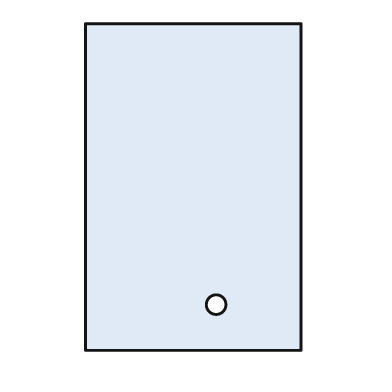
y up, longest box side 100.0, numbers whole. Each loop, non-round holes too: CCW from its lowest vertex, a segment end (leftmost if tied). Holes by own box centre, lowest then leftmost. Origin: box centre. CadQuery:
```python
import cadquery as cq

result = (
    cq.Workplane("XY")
    .moveTo(-33.0, -50.0)
    .lineTo(33.0, -50.0)
    .lineTo(33.0, 50.0)
    .lineTo(-33.0, 50.0)
    .close()
    .moveTo(7.0, -36.0)
    .circle(3.0)
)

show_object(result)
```